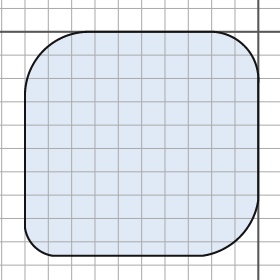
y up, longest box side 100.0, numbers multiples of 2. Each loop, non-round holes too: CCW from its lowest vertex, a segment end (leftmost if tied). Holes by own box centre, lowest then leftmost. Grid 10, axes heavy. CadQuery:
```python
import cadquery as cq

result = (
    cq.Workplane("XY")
    .moveTo(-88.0, -96.0)
    .lineTo(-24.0, -96.0)
    .threePointArc((-8.0, -88.0), (0.0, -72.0))
    .lineTo(0.0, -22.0)
    .threePointArc((-6.0, -6.0), (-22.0, 0.0))
    .lineTo(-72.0, 0.0)
    .threePointArc((-92.0, -8.0), (-100.0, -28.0))
    .lineTo(-100.0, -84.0)
    .threePointArc((-96.0, -92.0), (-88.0, -96.0))
    .close()
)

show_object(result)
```